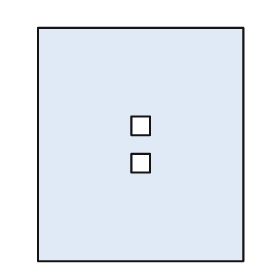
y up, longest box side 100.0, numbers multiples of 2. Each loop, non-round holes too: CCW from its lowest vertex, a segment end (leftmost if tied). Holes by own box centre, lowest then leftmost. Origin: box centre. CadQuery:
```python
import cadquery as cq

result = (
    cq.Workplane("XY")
    .moveTo(-44.0, -50.0)
    .lineTo(44.0, -50.0)
    .lineTo(44.0, 50.0)
    .lineTo(-44.0, 50.0)
    .close()
    .moveTo(-4.0, -12.0)
    .lineTo(4.0, -12.0)
    .lineTo(4.0, -4.0)
    .lineTo(-4.0, -4.0)
    .close()
    .moveTo(-4.0, 4.0)
    .lineTo(4.0, 4.0)
    .lineTo(4.0, 12.0)
    .lineTo(-4.0, 12.0)
    .close()
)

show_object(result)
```